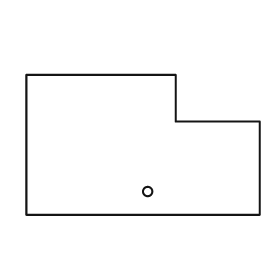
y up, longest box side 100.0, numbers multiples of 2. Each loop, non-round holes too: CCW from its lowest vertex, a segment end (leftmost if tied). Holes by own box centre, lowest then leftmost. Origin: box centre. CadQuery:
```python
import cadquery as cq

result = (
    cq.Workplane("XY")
    .moveTo(-50.0, -30.0)
    .lineTo(50.0, -30.0)
    .lineTo(50.0, 10.0)
    .lineTo(14.0, 10.0)
    .lineTo(14.0, 30.0)
    .lineTo(-50.0, 30.0)
    .close()
    .moveTo(2.0, -20.0)
    .circle(2.0)
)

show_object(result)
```